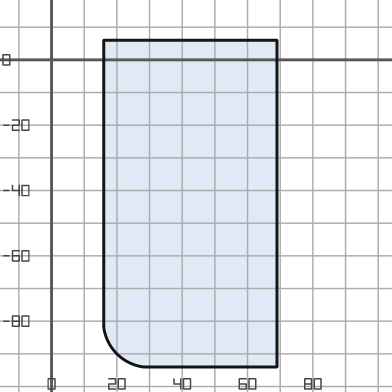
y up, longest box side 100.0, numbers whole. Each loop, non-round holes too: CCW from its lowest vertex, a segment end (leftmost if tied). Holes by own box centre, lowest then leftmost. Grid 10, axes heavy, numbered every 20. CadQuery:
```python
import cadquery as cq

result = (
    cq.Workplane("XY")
    .moveTo(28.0, -94.0)
    .lineTo(69.0, -94.0)
    .lineTo(69.0, 6.0)
    .lineTo(16.0, 6.0)
    .lineTo(16.0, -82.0)
    .threePointArc((20.0, -90.0), (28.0, -94.0))
    .close()
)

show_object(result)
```